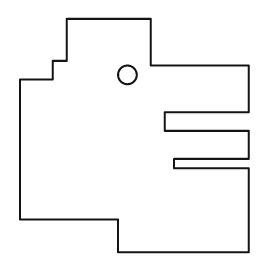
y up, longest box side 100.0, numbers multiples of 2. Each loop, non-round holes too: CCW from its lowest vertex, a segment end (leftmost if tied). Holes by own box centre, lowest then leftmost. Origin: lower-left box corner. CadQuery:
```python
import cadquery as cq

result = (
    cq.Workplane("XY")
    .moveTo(42.0, 0.0)
    .lineTo(98.0, 0.0)
    .lineTo(98.0, 36.0)
    .lineTo(66.0, 36.0)
    .lineTo(66.0, 40.0)
    .lineTo(98.0, 40.0)
    .lineTo(98.0, 52.0)
    .lineTo(62.0, 52.0)
    .lineTo(62.0, 60.0)
    .lineTo(98.0, 60.0)
    .lineTo(98.0, 80.0)
    .lineTo(56.0, 80.0)
    .lineTo(56.0, 100.0)
    .lineTo(20.0, 100.0)
    .lineTo(20.0, 82.0)
    .lineTo(14.0, 82.0)
    .lineTo(14.0, 74.0)
    .lineTo(0.0, 74.0)
    .lineTo(0.0, 14.0)
    .lineTo(42.0, 14.0)
    .close()
    .moveTo(46.0, 76.0)
    .circle(4.0)
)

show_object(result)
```